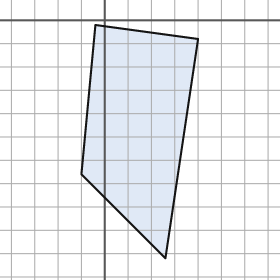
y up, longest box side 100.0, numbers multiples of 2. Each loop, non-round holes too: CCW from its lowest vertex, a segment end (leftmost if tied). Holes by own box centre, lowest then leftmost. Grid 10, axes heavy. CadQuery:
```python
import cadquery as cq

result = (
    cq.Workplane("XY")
    .moveTo(26.0, -102.0)
    .lineTo(40.0, -8.0)
    .lineTo(-4.0, -2.0)
    .lineTo(-10.0, -66.0)
    .close()
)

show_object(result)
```